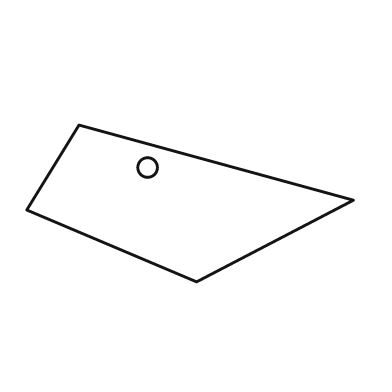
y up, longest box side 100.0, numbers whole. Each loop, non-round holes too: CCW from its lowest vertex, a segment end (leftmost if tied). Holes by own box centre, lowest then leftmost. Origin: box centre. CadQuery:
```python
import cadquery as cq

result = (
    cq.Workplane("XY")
    .moveTo(2.0, -24.0)
    .lineTo(50.0, 1.0)
    .lineTo(-34.0, 24.0)
    .lineTo(-50.0, -2.0)
    .close()
    .moveTo(-13.0, 11.0)
    .circle(3.0)
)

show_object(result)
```